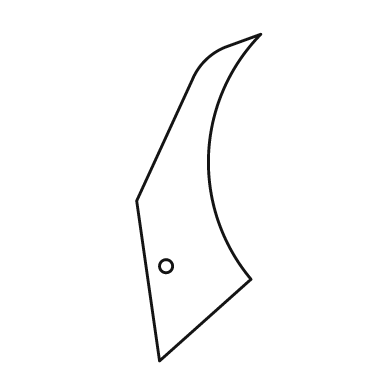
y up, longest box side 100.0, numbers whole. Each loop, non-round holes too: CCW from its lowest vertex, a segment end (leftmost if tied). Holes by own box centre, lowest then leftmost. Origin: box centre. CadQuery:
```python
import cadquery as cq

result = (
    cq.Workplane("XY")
    .moveTo(-12.0, -50.0)
    .lineTo(16.0, -25.0)
    .threePointArc((3.0, 13.0), (19.0, 50.0))
    .lineTo(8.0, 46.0)
    .threePointArc((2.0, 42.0), (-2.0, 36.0))
    .lineTo(-19.0, -1.0)
    .close()
    .moveTo(-10.0, -21.0)
    .circle(2.0)
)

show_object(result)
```